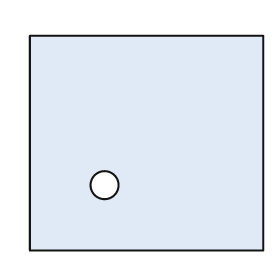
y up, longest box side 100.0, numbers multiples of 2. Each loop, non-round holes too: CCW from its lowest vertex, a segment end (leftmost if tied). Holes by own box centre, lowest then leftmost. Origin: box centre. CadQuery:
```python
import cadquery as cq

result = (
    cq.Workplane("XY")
    .moveTo(-50.0, -46.0)
    .lineTo(50.0, -46.0)
    .lineTo(50.0, 46.0)
    .lineTo(-50.0, 46.0)
    .close()
    .moveTo(-18.0, -18.0)
    .circle(6.0)
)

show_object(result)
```